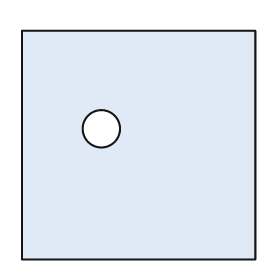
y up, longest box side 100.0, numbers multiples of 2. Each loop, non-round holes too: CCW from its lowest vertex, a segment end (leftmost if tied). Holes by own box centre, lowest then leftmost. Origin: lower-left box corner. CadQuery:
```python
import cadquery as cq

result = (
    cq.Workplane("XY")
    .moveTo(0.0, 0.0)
    .lineTo(100.0, 0.0)
    .lineTo(100.0, 98.0)
    .lineTo(0.0, 98.0)
    .close()
    .moveTo(34.0, 56.0)
    .circle(8.0)
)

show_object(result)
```